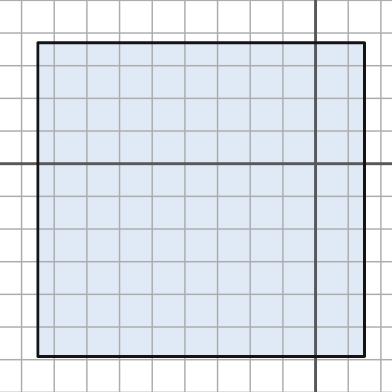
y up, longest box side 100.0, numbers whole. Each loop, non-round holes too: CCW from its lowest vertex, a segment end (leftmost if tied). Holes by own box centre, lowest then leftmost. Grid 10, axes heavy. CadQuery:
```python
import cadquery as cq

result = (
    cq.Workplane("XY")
    .moveTo(-85.0, -59.0)
    .lineTo(15.0, -59.0)
    .lineTo(15.0, 37.0)
    .lineTo(-85.0, 37.0)
    .close()
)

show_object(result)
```